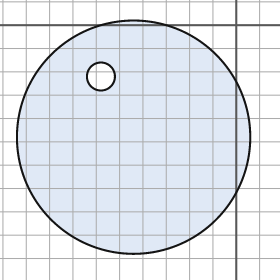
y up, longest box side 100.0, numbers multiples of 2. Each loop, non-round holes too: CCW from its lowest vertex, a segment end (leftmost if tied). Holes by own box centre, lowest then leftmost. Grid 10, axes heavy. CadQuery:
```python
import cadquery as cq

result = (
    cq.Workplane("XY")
    .moveTo(-44.0, -48.0)
    .circle(50.0)
    .moveTo(-58.0, -22.0)
    .circle(6.0)
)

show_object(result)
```